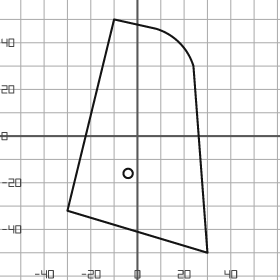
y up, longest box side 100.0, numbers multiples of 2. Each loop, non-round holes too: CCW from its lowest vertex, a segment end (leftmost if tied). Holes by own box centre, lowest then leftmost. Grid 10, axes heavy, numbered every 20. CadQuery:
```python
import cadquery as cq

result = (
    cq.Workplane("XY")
    .moveTo(30.0, -50.0)
    .lineTo(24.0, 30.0)
    .threePointArc((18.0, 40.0), (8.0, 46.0))
    .lineTo(-10.0, 50.0)
    .lineTo(-30.0, -32.0)
    .close()
    .moveTo(-4.0, -16.0)
    .circle(2.0)
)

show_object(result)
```